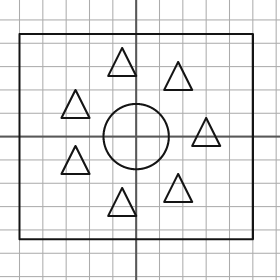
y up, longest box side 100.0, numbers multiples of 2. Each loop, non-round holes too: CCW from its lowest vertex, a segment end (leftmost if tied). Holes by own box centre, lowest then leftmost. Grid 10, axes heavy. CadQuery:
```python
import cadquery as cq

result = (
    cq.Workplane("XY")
    .moveTo(-50.0, -44.0)
    .lineTo(50.0, -44.0)
    .lineTo(50.0, 44.0)
    .lineTo(-50.0, 44.0)
    .close()
    .moveTo(-12.0, -34.0)
    .lineTo(0.0, -34.0)
    .lineTo(-6.0, -22.0)
    .close()
    .moveTo(12.0, -28.0)
    .lineTo(24.0, -28.0)
    .lineTo(18.0, -16.0)
    .close()
    .moveTo(-32.0, -16.0)
    .lineTo(-20.0, -16.0)
    .lineTo(-26.0, -4.0)
    .close()
    .moveTo(0.0, 0.0)
    .circle(14.0)
    .moveTo(24.0, -4.0)
    .lineTo(36.0, -4.0)
    .lineTo(30.0, 8.0)
    .close()
    .moveTo(-32.0, 8.0)
    .lineTo(-20.0, 8.0)
    .lineTo(-26.0, 20.0)
    .close()
    .moveTo(12.0, 20.0)
    .lineTo(24.0, 20.0)
    .lineTo(18.0, 32.0)
    .close()
    .moveTo(-12.0, 26.0)
    .lineTo(0.0, 26.0)
    .lineTo(-6.0, 38.0)
    .close()
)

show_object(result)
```